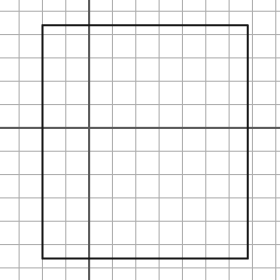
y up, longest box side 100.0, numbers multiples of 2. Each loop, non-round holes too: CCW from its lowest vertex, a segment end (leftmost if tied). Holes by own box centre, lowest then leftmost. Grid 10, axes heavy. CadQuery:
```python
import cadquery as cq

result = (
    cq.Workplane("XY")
    .moveTo(-20.0, -56.0)
    .lineTo(68.0, -56.0)
    .lineTo(68.0, 44.0)
    .lineTo(-20.0, 44.0)
    .close()
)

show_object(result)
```